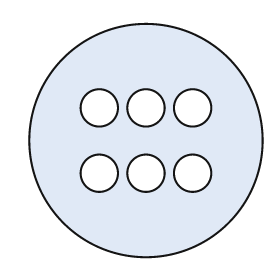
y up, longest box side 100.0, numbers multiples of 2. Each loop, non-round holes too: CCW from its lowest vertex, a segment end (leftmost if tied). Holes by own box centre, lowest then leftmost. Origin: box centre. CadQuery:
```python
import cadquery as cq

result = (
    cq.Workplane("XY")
    .moveTo(0.0, 0.0)
    .circle(50.0)
    .moveTo(-20.0, -14.0)
    .circle(8.0)
    .moveTo(0.0, -14.0)
    .circle(8.0)
    .moveTo(20.0, -14.0)
    .circle(8.0)
    .moveTo(-20.0, 14.0)
    .circle(8.0)
    .moveTo(0.0, 14.0)
    .circle(8.0)
    .moveTo(20.0, 14.0)
    .circle(8.0)
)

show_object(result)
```